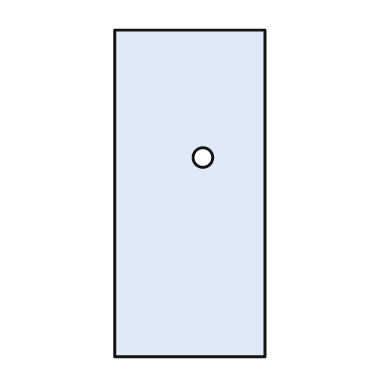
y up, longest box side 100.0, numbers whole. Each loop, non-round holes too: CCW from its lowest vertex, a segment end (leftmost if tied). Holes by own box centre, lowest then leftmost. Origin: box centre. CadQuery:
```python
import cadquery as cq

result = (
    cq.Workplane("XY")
    .moveTo(-23.0, -50.0)
    .lineTo(23.0, -50.0)
    .lineTo(23.0, 50.0)
    .lineTo(-23.0, 50.0)
    .close()
    .moveTo(4.0, 11.0)
    .circle(3.0)
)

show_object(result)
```